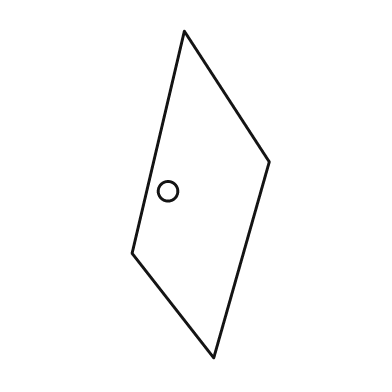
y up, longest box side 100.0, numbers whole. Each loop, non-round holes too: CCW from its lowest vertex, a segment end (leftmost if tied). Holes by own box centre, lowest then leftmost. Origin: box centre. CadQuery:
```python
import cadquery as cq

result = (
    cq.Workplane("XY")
    .moveTo(4.0, -50.0)
    .lineTo(21.0, 10.0)
    .lineTo(-5.0, 50.0)
    .lineTo(-21.0, -18.0)
    .close()
    .moveTo(-10.0, 1.0)
    .circle(3.0)
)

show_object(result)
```